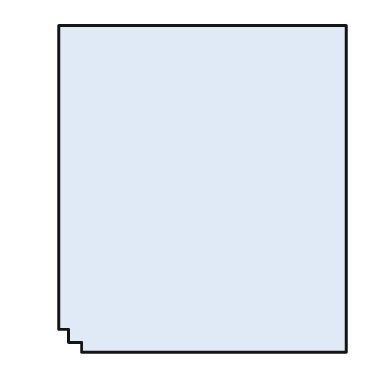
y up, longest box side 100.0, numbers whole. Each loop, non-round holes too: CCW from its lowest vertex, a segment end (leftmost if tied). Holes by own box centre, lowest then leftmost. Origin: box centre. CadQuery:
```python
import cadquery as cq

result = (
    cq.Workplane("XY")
    .moveTo(-37.0, -50.0)
    .lineTo(44.0, -50.0)
    .lineTo(44.0, 50.0)
    .lineTo(-44.0, 50.0)
    .lineTo(-44.0, -43.0)
    .lineTo(-41.0, -43.0)
    .lineTo(-41.0, -47.0)
    .lineTo(-37.0, -47.0)
    .close()
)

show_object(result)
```